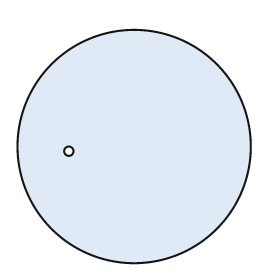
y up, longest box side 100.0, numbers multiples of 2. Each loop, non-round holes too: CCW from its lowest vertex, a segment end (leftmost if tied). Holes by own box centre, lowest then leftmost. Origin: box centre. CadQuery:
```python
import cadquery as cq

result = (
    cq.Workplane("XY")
    .moveTo(0.0, 0.0)
    .circle(50.0)
    .moveTo(-28.0, -2.0)
    .circle(2.0)
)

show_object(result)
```